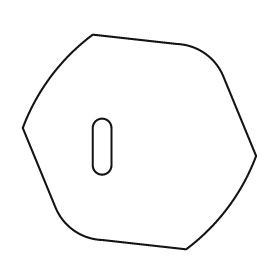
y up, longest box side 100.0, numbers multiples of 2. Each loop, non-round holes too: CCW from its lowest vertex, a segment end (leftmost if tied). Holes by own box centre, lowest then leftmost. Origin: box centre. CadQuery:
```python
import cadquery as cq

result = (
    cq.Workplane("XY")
    .moveTo(20.0, -46.0)
    .threePointArc((38.0, -28.0), (50.0, -6.0))
    .lineTo(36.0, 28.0)
    .threePointArc((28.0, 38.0), (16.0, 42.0))
    .lineTo(-20.0, 46.0)
    .threePointArc((-38.0, 28.0), (-50.0, 6.0))
    .lineTo(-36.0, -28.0)
    .threePointArc((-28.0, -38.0), (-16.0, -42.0))
    .close()
    .moveTo(-20.0, -10.0)
    .threePointArc((-16.0, -14.0), (-12.0, -10.0))
    .lineTo(-12.0, 6.0)
    .threePointArc((-16.0, 10.0), (-20.0, 6.0))
    .close()
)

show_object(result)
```